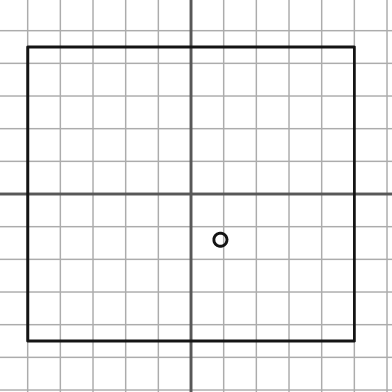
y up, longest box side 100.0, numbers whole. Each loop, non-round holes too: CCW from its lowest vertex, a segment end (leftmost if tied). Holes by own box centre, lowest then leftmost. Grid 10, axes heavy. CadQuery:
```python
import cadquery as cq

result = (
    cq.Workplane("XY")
    .moveTo(-50.0, -45.0)
    .lineTo(50.0, -45.0)
    .lineTo(50.0, 45.0)
    .lineTo(-50.0, 45.0)
    .close()
    .moveTo(9.0, -14.0)
    .circle(2.0)
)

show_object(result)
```